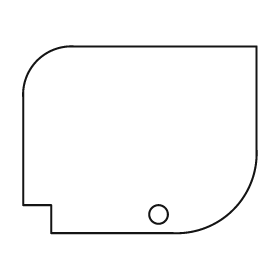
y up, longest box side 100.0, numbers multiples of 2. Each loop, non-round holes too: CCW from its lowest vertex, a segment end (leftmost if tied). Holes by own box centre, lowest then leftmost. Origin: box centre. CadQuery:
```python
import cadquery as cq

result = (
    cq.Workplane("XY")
    .moveTo(-38.0, -40.0)
    .lineTo(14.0, -40.0)
    .threePointArc((40.0, -30.0), (50.0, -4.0))
    .lineTo(50.0, 40.0)
    .lineTo(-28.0, 40.0)
    .threePointArc((-44.0, 34.0), (-50.0, 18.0))
    .lineTo(-50.0, -28.0)
    .lineTo(-38.0, -28.0)
    .close()
    .moveTo(8.0, -32.0)
    .circle(4.0)
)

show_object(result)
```